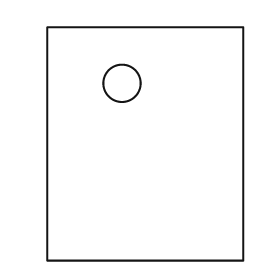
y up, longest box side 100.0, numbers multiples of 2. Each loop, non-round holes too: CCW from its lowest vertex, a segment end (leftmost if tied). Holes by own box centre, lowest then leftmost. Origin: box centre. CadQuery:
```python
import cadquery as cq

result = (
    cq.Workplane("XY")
    .moveTo(-42.0, -50.0)
    .lineTo(42.0, -50.0)
    .lineTo(42.0, 50.0)
    .lineTo(-42.0, 50.0)
    .close()
    .moveTo(-10.0, 26.0)
    .circle(8.0)
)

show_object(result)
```